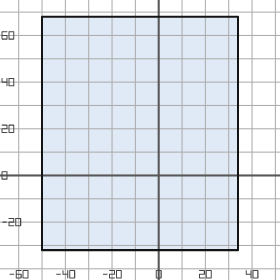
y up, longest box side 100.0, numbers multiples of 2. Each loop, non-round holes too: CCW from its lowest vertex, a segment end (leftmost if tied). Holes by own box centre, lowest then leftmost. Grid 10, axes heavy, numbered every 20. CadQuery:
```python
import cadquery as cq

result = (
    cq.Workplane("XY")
    .moveTo(-50.0, -32.0)
    .lineTo(34.0, -32.0)
    .lineTo(34.0, 68.0)
    .lineTo(-50.0, 68.0)
    .close()
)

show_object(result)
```